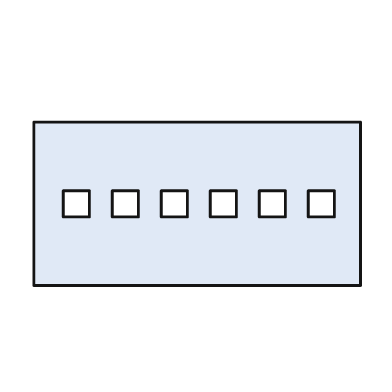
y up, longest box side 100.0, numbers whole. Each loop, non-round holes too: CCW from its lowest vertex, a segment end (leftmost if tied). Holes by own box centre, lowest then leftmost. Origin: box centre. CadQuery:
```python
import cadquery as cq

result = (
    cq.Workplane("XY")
    .moveTo(-50.0, -25.0)
    .lineTo(50.0, -25.0)
    .lineTo(50.0, 25.0)
    .lineTo(-50.0, 25.0)
    .close()
    .moveTo(-41.0, -4.0)
    .lineTo(-33.0, -4.0)
    .lineTo(-33.0, 4.0)
    .lineTo(-41.0, 4.0)
    .close()
    .moveTo(-26.0, -4.0)
    .lineTo(-18.0, -4.0)
    .lineTo(-18.0, 4.0)
    .lineTo(-26.0, 4.0)
    .close()
    .moveTo(-11.0, -4.0)
    .lineTo(-3.0, -4.0)
    .lineTo(-3.0, 4.0)
    .lineTo(-11.0, 4.0)
    .close()
    .moveTo(4.0, -4.0)
    .lineTo(12.0, -4.0)
    .lineTo(12.0, 4.0)
    .lineTo(4.0, 4.0)
    .close()
    .moveTo(19.0, -4.0)
    .lineTo(27.0, -4.0)
    .lineTo(27.0, 4.0)
    .lineTo(19.0, 4.0)
    .close()
    .moveTo(34.0, -4.0)
    .lineTo(42.0, -4.0)
    .lineTo(42.0, 4.0)
    .lineTo(34.0, 4.0)
    .close()
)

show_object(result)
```